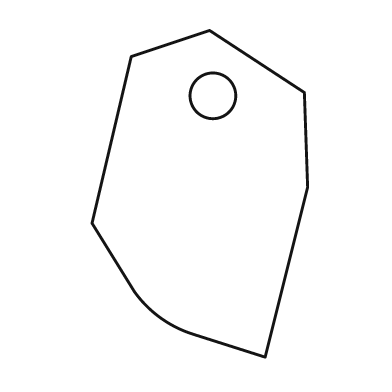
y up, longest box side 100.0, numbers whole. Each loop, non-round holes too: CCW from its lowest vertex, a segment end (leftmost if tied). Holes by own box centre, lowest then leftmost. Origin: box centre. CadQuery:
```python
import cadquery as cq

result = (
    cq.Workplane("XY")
    .moveTo(20.0, -50.0)
    .lineTo(33.0, 2.0)
    .lineTo(32.0, 31.0)
    .lineTo(3.0, 50.0)
    .lineTo(-21.0, 42.0)
    .lineTo(-33.0, -9.0)
    .lineTo(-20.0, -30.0)
    .threePointArc((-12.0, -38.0), (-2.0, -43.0))
    .close()
    .moveTo(4.0, 30.0)
    .circle(7.0)
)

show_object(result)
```